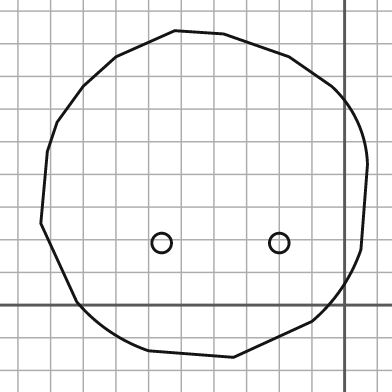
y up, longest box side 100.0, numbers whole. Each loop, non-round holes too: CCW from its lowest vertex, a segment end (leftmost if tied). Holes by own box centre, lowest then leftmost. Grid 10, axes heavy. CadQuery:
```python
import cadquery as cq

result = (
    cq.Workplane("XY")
    .moveTo(-34.0, -16.0)
    .lineTo(-10.0, -5.0)
    .threePointArc((-1.0, 5.0), (5.0, 17.0))
    .lineTo(7.0, 43.0)
    .threePointArc((4.0, 56.0), (-4.0, 67.0))
    .lineTo(-17.0, 76.0)
    .lineTo(-37.0, 83.0)
    .lineTo(-52.0, 84.0)
    .lineTo(-70.0, 76.0)
    .lineTo(-80.0, 67.0)
    .lineTo(-88.0, 56.0)
    .lineTo(-91.0, 47.0)
    .lineTo(-93.0, 25.0)
    .lineTo(-82.0, 1.0)
    .threePointArc((-72.0, -8.0), (-60.0, -14.0))
    .close()
    .moveTo(-56.0, 19.0)
    .circle(3.0)
    .moveTo(-20.0, 19.0)
    .circle(3.0)
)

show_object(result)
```